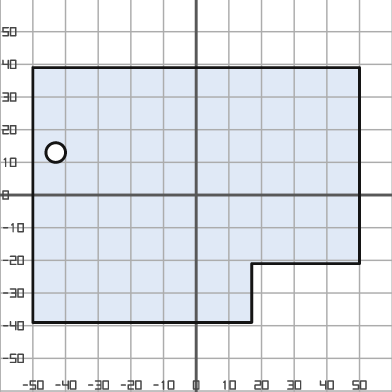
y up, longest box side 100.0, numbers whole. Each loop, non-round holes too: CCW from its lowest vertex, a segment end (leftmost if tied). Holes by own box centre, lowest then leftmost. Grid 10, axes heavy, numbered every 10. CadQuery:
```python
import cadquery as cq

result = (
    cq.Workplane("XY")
    .moveTo(-50.0, -39.0)
    .lineTo(17.0, -39.0)
    .lineTo(17.0, -21.0)
    .lineTo(50.0, -21.0)
    .lineTo(50.0, 39.0)
    .lineTo(-50.0, 39.0)
    .close()
    .moveTo(-43.0, 13.0)
    .circle(3.0)
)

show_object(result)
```